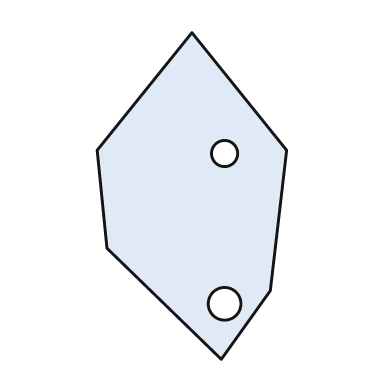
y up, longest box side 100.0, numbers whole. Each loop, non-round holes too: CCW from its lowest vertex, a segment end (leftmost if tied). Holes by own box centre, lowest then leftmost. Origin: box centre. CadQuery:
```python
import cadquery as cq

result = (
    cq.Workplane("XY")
    .moveTo(9.0, -50.0)
    .lineTo(24.0, -29.0)
    .lineTo(29.0, 14.0)
    .lineTo(0.0, 50.0)
    .lineTo(-29.0, 14.0)
    .lineTo(-26.0, -16.0)
    .close()
    .moveTo(10.0, -33.0)
    .circle(5.0)
    .moveTo(10.0, 13.0)
    .circle(4.0)
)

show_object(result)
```